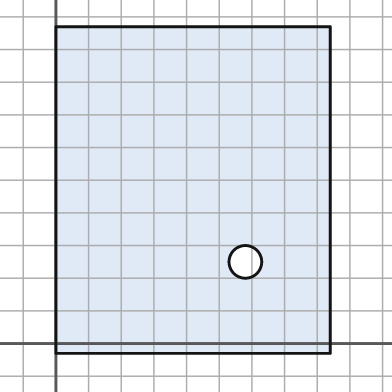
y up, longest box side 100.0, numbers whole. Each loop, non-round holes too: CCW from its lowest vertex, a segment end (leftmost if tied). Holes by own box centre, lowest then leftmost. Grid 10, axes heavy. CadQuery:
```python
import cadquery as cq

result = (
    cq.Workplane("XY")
    .moveTo(0.0, -3.0)
    .lineTo(84.0, -3.0)
    .lineTo(84.0, 97.0)
    .lineTo(0.0, 97.0)
    .close()
    .moveTo(58.0, 25.0)
    .circle(5.0)
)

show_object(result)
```